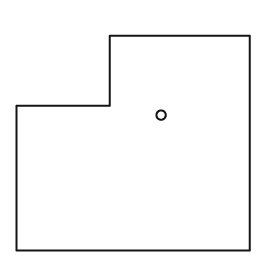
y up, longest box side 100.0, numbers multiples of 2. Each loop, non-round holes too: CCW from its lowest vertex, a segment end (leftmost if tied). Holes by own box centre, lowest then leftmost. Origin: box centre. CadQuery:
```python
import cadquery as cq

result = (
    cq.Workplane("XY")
    .moveTo(-50.0, -46.0)
    .lineTo(50.0, -46.0)
    .lineTo(50.0, 46.0)
    .lineTo(-10.0, 46.0)
    .lineTo(-10.0, 16.0)
    .lineTo(-50.0, 16.0)
    .close()
    .moveTo(12.0, 12.0)
    .circle(2.0)
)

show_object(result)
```